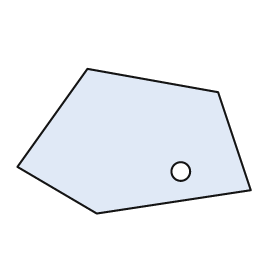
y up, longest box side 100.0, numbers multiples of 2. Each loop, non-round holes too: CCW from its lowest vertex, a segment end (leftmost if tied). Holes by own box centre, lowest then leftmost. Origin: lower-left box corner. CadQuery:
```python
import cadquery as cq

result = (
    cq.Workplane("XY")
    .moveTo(34.0, 0.0)
    .lineTo(100.0, 10.0)
    .lineTo(86.0, 52.0)
    .lineTo(30.0, 62.0)
    .lineTo(0.0, 20.0)
    .close()
    .moveTo(70.0, 18.0)
    .circle(4.0)
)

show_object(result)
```